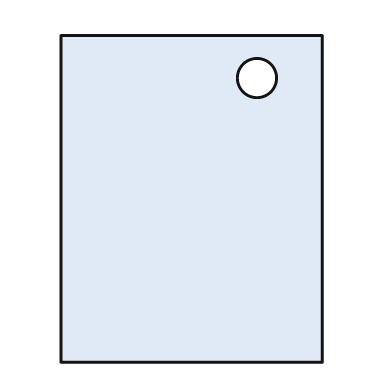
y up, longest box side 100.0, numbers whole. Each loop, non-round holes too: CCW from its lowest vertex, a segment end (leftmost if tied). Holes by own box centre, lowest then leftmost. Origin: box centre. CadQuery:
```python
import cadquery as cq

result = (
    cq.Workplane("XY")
    .moveTo(-40.0, -50.0)
    .lineTo(40.0, -50.0)
    .lineTo(40.0, 50.0)
    .lineTo(-40.0, 50.0)
    .close()
    .moveTo(20.0, 37.0)
    .circle(6.0)
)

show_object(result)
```